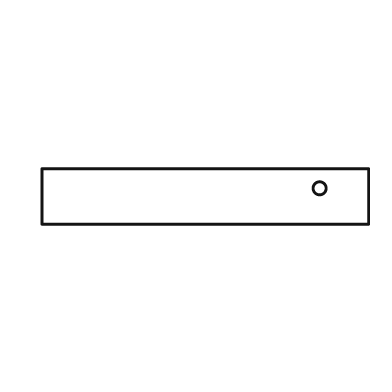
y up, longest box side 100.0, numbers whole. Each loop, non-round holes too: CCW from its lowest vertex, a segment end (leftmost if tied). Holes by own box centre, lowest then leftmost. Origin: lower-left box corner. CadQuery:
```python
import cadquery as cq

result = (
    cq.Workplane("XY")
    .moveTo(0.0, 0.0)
    .lineTo(100.0, 0.0)
    .lineTo(100.0, 17.0)
    .lineTo(0.0, 17.0)
    .close()
    .moveTo(85.0, 11.0)
    .circle(2.0)
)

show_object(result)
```